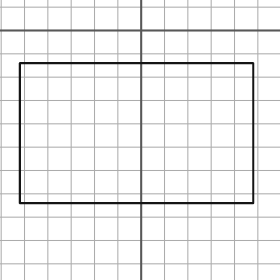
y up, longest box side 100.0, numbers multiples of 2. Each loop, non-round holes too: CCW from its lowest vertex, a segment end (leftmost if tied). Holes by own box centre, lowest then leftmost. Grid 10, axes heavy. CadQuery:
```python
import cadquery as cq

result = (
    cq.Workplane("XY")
    .moveTo(-52.0, -74.0)
    .lineTo(48.0, -74.0)
    .lineTo(48.0, -14.0)
    .lineTo(-52.0, -14.0)
    .close()
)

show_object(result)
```